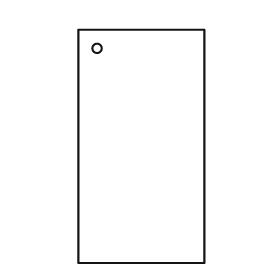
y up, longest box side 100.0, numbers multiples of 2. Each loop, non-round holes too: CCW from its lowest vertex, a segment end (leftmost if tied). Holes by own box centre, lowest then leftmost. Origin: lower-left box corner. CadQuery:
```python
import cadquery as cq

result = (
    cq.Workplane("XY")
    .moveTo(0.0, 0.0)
    .lineTo(54.0, 0.0)
    .lineTo(54.0, 100.0)
    .lineTo(0.0, 100.0)
    .close()
    .moveTo(8.0, 92.0)
    .circle(2.0)
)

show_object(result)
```